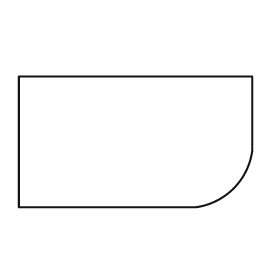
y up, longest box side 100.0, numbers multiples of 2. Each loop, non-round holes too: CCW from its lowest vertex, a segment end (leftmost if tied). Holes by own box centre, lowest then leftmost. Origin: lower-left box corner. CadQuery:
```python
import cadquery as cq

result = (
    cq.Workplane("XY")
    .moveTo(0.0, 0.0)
    .lineTo(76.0, 0.0)
    .threePointArc((92.0, 8.0), (100.0, 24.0))
    .lineTo(100.0, 56.0)
    .lineTo(0.0, 56.0)
    .close()
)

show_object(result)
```